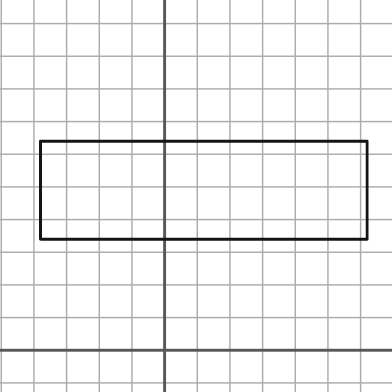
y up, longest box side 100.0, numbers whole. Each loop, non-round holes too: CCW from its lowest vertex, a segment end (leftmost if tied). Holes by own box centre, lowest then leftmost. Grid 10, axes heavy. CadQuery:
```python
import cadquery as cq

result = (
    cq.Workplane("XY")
    .moveTo(-38.0, 34.0)
    .lineTo(62.0, 34.0)
    .lineTo(62.0, 64.0)
    .lineTo(-38.0, 64.0)
    .close()
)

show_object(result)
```